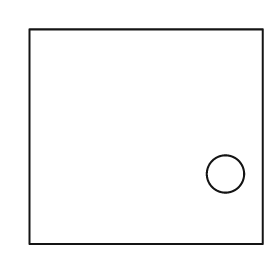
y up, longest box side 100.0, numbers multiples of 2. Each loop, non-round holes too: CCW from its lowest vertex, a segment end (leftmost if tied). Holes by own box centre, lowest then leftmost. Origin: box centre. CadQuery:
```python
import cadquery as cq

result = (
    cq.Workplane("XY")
    .moveTo(-50.0, -46.0)
    .lineTo(50.0, -46.0)
    .lineTo(50.0, 46.0)
    .lineTo(-50.0, 46.0)
    .close()
    .moveTo(34.0, -16.0)
    .circle(8.0)
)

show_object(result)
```